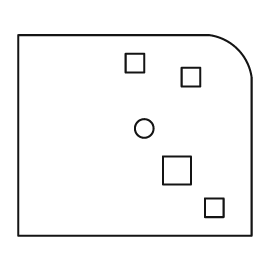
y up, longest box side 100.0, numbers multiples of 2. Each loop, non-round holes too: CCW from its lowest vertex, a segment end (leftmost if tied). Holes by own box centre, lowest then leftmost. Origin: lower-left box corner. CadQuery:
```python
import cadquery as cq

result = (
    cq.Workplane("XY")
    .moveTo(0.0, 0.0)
    .lineTo(100.0, 0.0)
    .lineTo(100.0, 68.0)
    .threePointArc((94.0, 80.0), (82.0, 86.0))
    .lineTo(0.0, 86.0)
    .close()
    .moveTo(80.0, 8.0)
    .lineTo(88.0, 8.0)
    .lineTo(88.0, 16.0)
    .lineTo(80.0, 16.0)
    .close()
    .moveTo(62.0, 22.0)
    .lineTo(74.0, 22.0)
    .lineTo(74.0, 34.0)
    .lineTo(62.0, 34.0)
    .close()
    .moveTo(54.0, 46.0)
    .circle(4.0)
    .moveTo(70.0, 64.0)
    .lineTo(78.0, 64.0)
    .lineTo(78.0, 72.0)
    .lineTo(70.0, 72.0)
    .close()
    .moveTo(46.0, 70.0)
    .lineTo(54.0, 70.0)
    .lineTo(54.0, 78.0)
    .lineTo(46.0, 78.0)
    .close()
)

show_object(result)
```